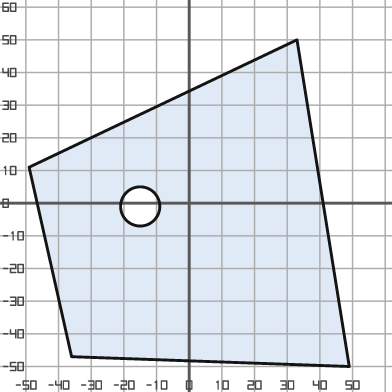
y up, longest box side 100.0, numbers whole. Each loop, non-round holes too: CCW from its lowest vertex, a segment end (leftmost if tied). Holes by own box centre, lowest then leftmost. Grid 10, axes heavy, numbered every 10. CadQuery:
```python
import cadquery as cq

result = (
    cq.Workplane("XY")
    .moveTo(49.0, -50.0)
    .lineTo(33.0, 50.0)
    .lineTo(-49.0, 11.0)
    .lineTo(-36.0, -47.0)
    .close()
    .moveTo(-15.0, -1.0)
    .circle(6.0)
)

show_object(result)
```